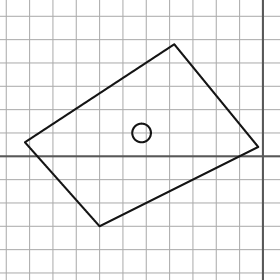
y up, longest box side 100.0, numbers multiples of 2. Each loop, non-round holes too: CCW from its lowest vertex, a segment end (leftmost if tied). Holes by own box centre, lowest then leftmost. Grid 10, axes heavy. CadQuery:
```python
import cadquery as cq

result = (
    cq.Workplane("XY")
    .moveTo(-70.0, -30.0)
    .lineTo(-2.0, 4.0)
    .lineTo(-38.0, 48.0)
    .lineTo(-102.0, 6.0)
    .close()
    .moveTo(-52.0, 10.0)
    .circle(4.0)
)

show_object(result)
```